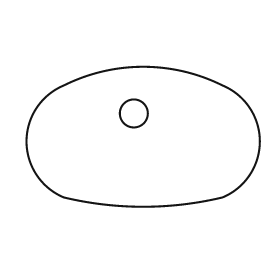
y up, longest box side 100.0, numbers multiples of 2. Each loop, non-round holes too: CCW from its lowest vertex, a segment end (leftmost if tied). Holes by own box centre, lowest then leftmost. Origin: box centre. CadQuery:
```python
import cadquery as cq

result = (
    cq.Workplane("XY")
    .moveTo(-34.0, -26.0)
    .threePointArc((0.0, -30.0), (34.0, -26.0))
    .threePointArc((50.0, -2.0), (34.0, 22.0))
    .threePointArc((0.0, 30.0), (-34.0, 22.0))
    .threePointArc((-50.0, -2.0), (-34.0, -26.0))
    .close()
    .moveTo(-4.0, 10.0)
    .circle(6.0)
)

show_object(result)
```